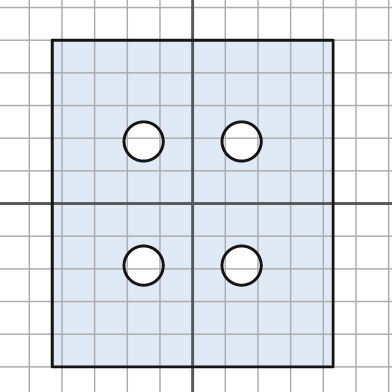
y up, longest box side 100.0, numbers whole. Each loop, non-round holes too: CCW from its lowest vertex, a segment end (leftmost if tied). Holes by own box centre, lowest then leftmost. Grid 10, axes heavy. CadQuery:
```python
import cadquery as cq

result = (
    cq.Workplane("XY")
    .moveTo(-43.0, -50.0)
    .lineTo(43.0, -50.0)
    .lineTo(43.0, 50.0)
    .lineTo(-43.0, 50.0)
    .close()
    .moveTo(-15.0, -19.0)
    .circle(6.0)
    .moveTo(15.0, -19.0)
    .circle(6.0)
    .moveTo(-15.0, 19.0)
    .circle(6.0)
    .moveTo(15.0, 19.0)
    .circle(6.0)
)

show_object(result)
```